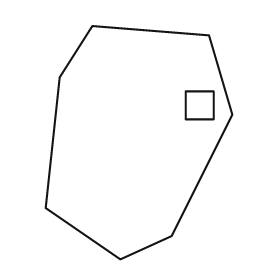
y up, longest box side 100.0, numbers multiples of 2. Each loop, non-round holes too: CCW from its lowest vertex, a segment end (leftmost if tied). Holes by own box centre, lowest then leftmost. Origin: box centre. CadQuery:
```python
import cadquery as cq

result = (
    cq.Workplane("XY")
    .moveTo(-8.0, -50.0)
    .lineTo(14.0, -40.0)
    .lineTo(40.0, 12.0)
    .lineTo(30.0, 46.0)
    .lineTo(-20.0, 50.0)
    .lineTo(-34.0, 28.0)
    .lineTo(-40.0, -28.0)
    .close()
    .moveTo(20.0, 10.0)
    .lineTo(32.0, 10.0)
    .lineTo(32.0, 22.0)
    .lineTo(20.0, 22.0)
    .close()
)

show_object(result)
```